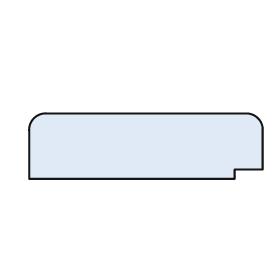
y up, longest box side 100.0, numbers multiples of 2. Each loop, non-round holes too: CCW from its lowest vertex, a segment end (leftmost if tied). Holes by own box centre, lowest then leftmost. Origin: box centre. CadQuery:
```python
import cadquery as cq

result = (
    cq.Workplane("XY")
    .moveTo(-50.0, -14.0)
    .lineTo(38.0, -14.0)
    .lineTo(38.0, -10.0)
    .lineTo(50.0, -10.0)
    .lineTo(50.0, 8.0)
    .threePointArc((48.0, 12.0), (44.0, 14.0))
    .lineTo(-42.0, 14.0)
    .threePointArc((-48.0, 12.0), (-50.0, 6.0))
    .close()
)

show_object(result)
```